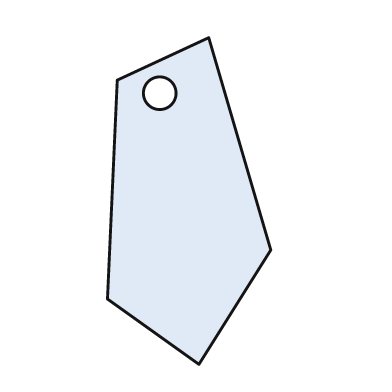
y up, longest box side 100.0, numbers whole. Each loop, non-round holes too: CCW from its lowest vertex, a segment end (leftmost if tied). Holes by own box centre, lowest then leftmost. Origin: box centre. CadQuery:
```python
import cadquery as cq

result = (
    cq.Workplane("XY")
    .moveTo(3.0, -50.0)
    .lineTo(25.0, -15.0)
    .lineTo(6.0, 50.0)
    .lineTo(-22.0, 37.0)
    .lineTo(-25.0, -30.0)
    .close()
    .moveTo(-9.0, 33.0)
    .circle(5.0)
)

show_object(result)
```